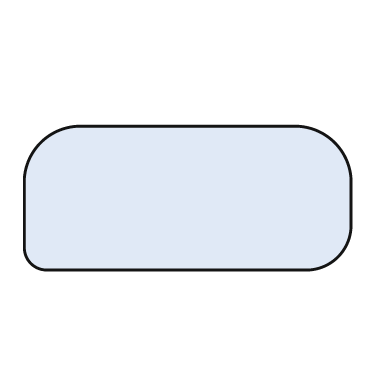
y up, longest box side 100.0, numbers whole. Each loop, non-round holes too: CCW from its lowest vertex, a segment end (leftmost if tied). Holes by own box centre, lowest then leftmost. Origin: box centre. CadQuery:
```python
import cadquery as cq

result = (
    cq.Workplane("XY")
    .moveTo(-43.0, -22.0)
    .lineTo(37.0, -22.0)
    .threePointArc((46.0, -18.0), (50.0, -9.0))
    .lineTo(50.0, 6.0)
    .threePointArc((45.0, 17.0), (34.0, 22.0))
    .lineTo(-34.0, 22.0)
    .threePointArc((-45.0, 17.0), (-50.0, 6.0))
    .lineTo(-50.0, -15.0)
    .threePointArc((-48.0, -20.0), (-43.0, -22.0))
    .close()
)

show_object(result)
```